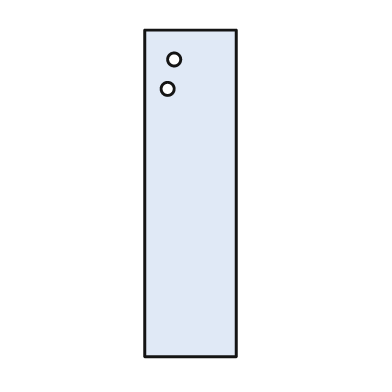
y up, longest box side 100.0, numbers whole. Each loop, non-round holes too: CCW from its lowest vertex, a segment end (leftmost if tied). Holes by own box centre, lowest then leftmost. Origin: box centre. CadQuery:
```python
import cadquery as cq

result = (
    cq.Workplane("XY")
    .moveTo(-14.0, -50.0)
    .lineTo(14.0, -50.0)
    .lineTo(14.0, 50.0)
    .lineTo(-14.0, 50.0)
    .close()
    .moveTo(-7.0, 32.0)
    .circle(2.0)
    .moveTo(-5.0, 41.0)
    .circle(2.0)
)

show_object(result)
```